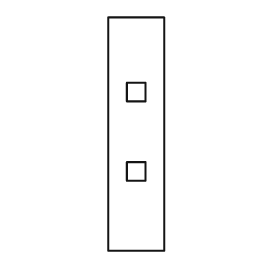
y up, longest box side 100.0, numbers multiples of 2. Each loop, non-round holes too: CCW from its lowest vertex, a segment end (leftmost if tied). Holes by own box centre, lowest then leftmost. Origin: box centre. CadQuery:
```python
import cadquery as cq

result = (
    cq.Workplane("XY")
    .moveTo(-12.0, -50.0)
    .lineTo(12.0, -50.0)
    .lineTo(12.0, 50.0)
    .lineTo(-12.0, 50.0)
    .close()
    .moveTo(-4.0, -20.0)
    .lineTo(4.0, -20.0)
    .lineTo(4.0, -12.0)
    .lineTo(-4.0, -12.0)
    .close()
    .moveTo(-4.0, 14.0)
    .lineTo(4.0, 14.0)
    .lineTo(4.0, 22.0)
    .lineTo(-4.0, 22.0)
    .close()
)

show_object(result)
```